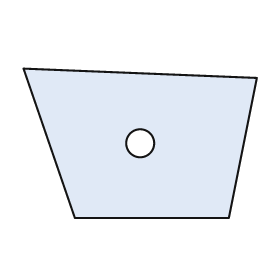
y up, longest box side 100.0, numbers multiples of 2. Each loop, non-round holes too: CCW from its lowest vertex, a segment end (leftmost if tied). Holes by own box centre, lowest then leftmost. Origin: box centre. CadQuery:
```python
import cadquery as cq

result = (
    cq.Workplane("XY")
    .moveTo(-28.0, -32.0)
    .lineTo(38.0, -32.0)
    .lineTo(50.0, 28.0)
    .lineTo(-50.0, 32.0)
    .close()
    .moveTo(0.0, 0.0)
    .circle(6.0)
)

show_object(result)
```